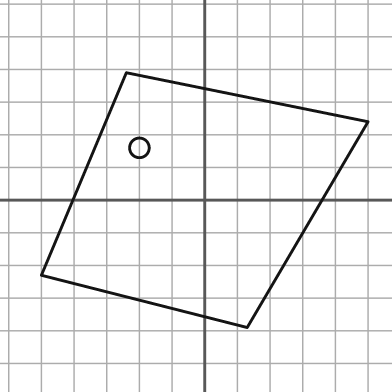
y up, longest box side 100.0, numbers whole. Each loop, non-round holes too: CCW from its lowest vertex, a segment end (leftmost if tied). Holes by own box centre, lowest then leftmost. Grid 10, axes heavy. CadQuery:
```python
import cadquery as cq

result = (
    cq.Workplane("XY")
    .moveTo(13.0, -39.0)
    .lineTo(50.0, 24.0)
    .lineTo(-24.0, 39.0)
    .lineTo(-50.0, -23.0)
    .close()
    .moveTo(-20.0, 16.0)
    .circle(3.0)
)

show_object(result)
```